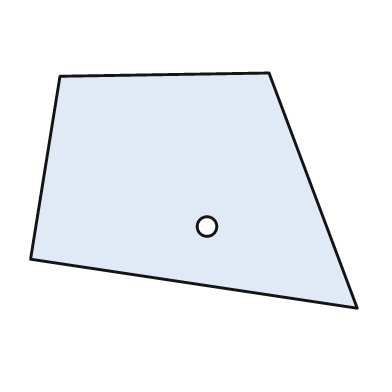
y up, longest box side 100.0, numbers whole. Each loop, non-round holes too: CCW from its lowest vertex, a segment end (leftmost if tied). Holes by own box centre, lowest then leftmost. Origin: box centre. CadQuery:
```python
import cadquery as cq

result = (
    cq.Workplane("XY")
    .moveTo(50.0, -36.0)
    .lineTo(23.0, 36.0)
    .lineTo(-41.0, 35.0)
    .lineTo(-50.0, -21.0)
    .close()
    .moveTo(4.0, -11.0)
    .circle(3.0)
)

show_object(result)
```